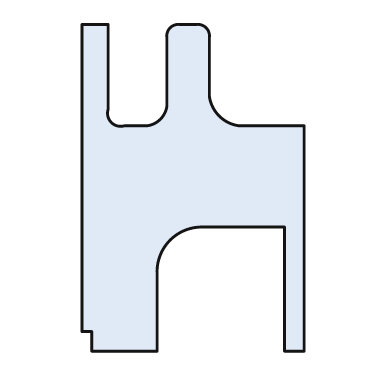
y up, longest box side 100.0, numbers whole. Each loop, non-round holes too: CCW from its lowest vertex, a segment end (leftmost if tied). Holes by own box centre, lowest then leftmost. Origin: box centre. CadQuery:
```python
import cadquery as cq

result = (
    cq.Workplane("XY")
    .moveTo(-31.0, -50.0)
    .lineTo(-11.0, -50.0)
    .lineTo(-11.0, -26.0)
    .threePointArc((-7.0, -16.0), (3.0, -12.0))
    .lineTo(28.0, -12.0)
    .lineTo(28.0, -50.0)
    .lineTo(34.0, -50.0)
    .lineTo(34.0, 19.0)
    .lineTo(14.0, 19.0)
    .threePointArc((8.0, 22.0), (5.0, 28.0))
    .lineTo(5.0, 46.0)
    .threePointArc((4.0, 49.0), (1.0, 50.0))
    .lineTo(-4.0, 50.0)
    .threePointArc((-7.0, 49.0), (-8.0, 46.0))
    .lineTo(-8.0, 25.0)
    .threePointArc((-10.0, 21.0), (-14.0, 19.0))
    .lineTo(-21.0, 19.0)
    .threePointArc((-25.0, 20.0), (-26.0, 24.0))
    .lineTo(-26.0, 50.0)
    .lineTo(-34.0, 50.0)
    .lineTo(-34.0, -44.0)
    .lineTo(-31.0, -44.0)
    .close()
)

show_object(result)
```